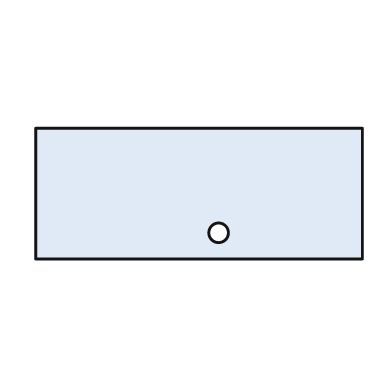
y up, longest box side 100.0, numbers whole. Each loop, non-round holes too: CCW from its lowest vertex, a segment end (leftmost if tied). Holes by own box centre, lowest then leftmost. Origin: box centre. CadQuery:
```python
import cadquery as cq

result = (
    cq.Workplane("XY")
    .moveTo(-50.0, -20.0)
    .lineTo(50.0, -20.0)
    .lineTo(50.0, 20.0)
    .lineTo(-50.0, 20.0)
    .close()
    .moveTo(6.0, -12.0)
    .circle(3.0)
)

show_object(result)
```